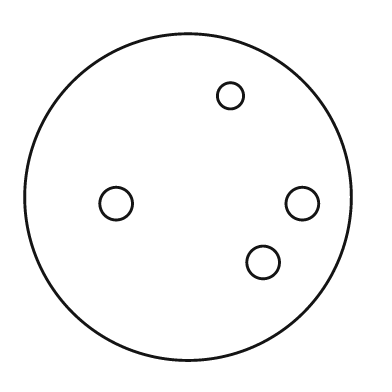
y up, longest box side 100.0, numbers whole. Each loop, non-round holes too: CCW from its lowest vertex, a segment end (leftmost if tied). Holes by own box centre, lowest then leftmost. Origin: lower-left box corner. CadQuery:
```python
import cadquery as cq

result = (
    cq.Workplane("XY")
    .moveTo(50.0, 50.0)
    .circle(50.0)
    .moveTo(73.0, 30.0)
    .circle(5.0)
    .moveTo(28.0, 48.0)
    .circle(5.0)
    .moveTo(85.0, 48.0)
    .circle(5.0)
    .moveTo(63.0, 81.0)
    .circle(4.0)
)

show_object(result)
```